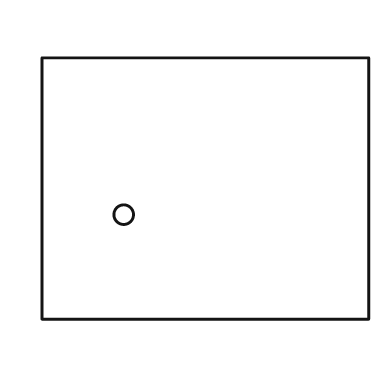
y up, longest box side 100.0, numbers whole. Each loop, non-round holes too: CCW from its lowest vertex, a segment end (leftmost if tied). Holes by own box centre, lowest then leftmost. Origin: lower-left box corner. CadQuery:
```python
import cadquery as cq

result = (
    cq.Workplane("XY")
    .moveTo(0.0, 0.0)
    .lineTo(100.0, 0.0)
    .lineTo(100.0, 80.0)
    .lineTo(0.0, 80.0)
    .close()
    .moveTo(25.0, 32.0)
    .circle(3.0)
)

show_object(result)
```